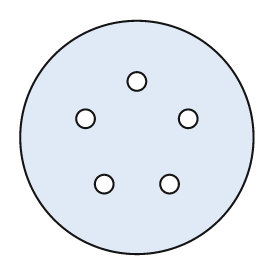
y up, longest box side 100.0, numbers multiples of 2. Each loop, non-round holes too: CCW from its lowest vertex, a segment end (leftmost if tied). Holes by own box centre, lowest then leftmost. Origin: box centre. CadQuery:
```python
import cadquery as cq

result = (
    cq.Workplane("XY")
    .moveTo(0.0, 0.0)
    .circle(50.0)
    .moveTo(-14.0, -20.0)
    .circle(4.0)
    .moveTo(14.0, -20.0)
    .circle(4.0)
    .moveTo(-22.0, 8.0)
    .circle(4.0)
    .moveTo(22.0, 8.0)
    .circle(4.0)
    .moveTo(0.0, 24.0)
    .circle(4.0)
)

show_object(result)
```